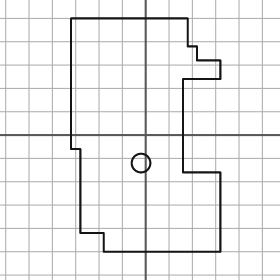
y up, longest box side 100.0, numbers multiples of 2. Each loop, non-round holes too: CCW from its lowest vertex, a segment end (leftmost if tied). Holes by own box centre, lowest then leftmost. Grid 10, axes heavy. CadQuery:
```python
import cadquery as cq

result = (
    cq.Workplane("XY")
    .moveTo(-18.0, -50.0)
    .lineTo(32.0, -50.0)
    .lineTo(32.0, -16.0)
    .lineTo(16.0, -16.0)
    .lineTo(16.0, 24.0)
    .lineTo(32.0, 24.0)
    .lineTo(32.0, 32.0)
    .lineTo(22.0, 32.0)
    .lineTo(22.0, 38.0)
    .lineTo(18.0, 38.0)
    .lineTo(18.0, 50.0)
    .lineTo(-32.0, 50.0)
    .lineTo(-32.0, -6.0)
    .lineTo(-28.0, -6.0)
    .lineTo(-28.0, -42.0)
    .lineTo(-18.0, -42.0)
    .close()
    .moveTo(-2.0, -12.0)
    .circle(4.0)
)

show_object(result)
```